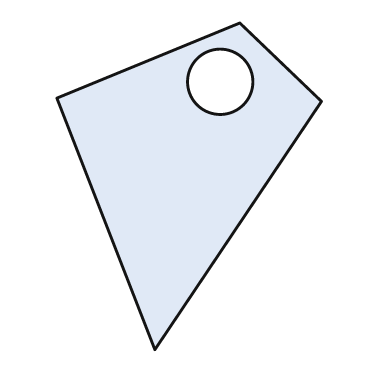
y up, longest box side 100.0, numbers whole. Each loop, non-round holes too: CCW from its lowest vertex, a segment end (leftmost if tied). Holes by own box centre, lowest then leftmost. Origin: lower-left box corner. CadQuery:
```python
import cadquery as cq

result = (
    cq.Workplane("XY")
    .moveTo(30.0, 0.0)
    .lineTo(81.0, 76.0)
    .lineTo(56.0, 100.0)
    .lineTo(0.0, 77.0)
    .close()
    .moveTo(50.0, 82.0)
    .circle(10.0)
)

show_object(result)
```